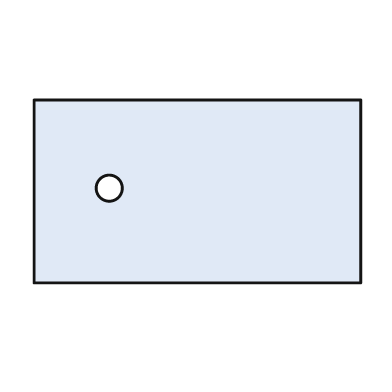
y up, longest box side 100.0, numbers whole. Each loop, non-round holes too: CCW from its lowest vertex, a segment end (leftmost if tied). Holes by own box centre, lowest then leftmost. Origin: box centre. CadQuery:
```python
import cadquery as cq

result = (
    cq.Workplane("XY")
    .moveTo(-50.0, -28.0)
    .lineTo(50.0, -28.0)
    .lineTo(50.0, 28.0)
    .lineTo(-50.0, 28.0)
    .close()
    .moveTo(-27.0, 1.0)
    .circle(4.0)
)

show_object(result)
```